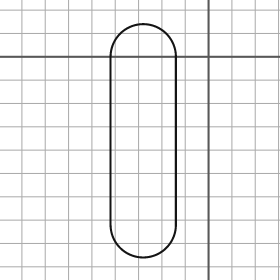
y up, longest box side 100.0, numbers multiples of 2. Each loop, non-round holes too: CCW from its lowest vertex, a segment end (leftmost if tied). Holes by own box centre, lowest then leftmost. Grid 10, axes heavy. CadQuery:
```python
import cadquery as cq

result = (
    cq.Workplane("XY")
    .moveTo(-42.0, -72.0)
    .threePointArc((-28.0, -86.0), (-14.0, -72.0))
    .lineTo(-14.0, 0.0)
    .threePointArc((-28.0, 14.0), (-42.0, 0.0))
    .close()
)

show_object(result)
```